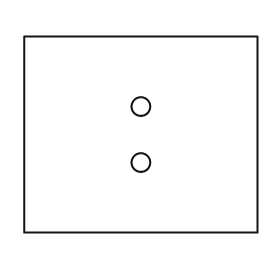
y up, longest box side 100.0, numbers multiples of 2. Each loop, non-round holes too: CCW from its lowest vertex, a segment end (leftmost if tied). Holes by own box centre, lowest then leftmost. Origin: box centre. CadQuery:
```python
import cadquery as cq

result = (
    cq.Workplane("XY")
    .moveTo(-50.0, -42.0)
    .lineTo(50.0, -42.0)
    .lineTo(50.0, 42.0)
    .lineTo(-50.0, 42.0)
    .close()
    .moveTo(0.0, -12.0)
    .circle(4.0)
    .moveTo(0.0, 12.0)
    .circle(4.0)
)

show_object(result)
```